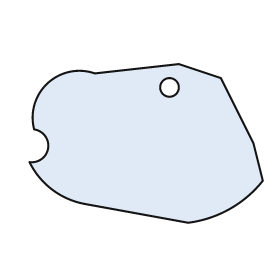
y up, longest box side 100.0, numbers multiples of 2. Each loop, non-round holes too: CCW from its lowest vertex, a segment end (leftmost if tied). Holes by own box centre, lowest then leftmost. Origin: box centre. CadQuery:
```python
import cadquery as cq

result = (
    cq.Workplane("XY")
    .moveTo(18.0, -34.0)
    .threePointArc((36.0, -28.0), (50.0, -16.0))
    .lineTo(46.0, 0.0)
    .lineTo(32.0, 28.0)
    .lineTo(14.0, 34.0)
    .lineTo(-22.0, 30.0)
    .threePointArc((-42.0, 26.0), (-48.0, 6.0))
    .threePointArc((-42.0, -2.0), (-50.0, -8.0))
    .threePointArc((-40.0, -20.0), (-26.0, -26.0))
    .close()
    .moveTo(10.0, 24.0)
    .circle(4.0)
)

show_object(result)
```